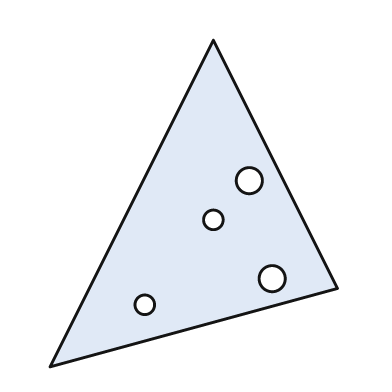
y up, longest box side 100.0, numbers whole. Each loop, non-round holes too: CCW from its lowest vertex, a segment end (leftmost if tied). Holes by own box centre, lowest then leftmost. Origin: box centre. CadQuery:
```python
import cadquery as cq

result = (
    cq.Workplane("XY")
    .moveTo(-44.0, -50.0)
    .lineTo(44.0, -26.0)
    .lineTo(6.0, 50.0)
    .close()
    .moveTo(-15.0, -31.0)
    .circle(3.0)
    .moveTo(24.0, -23.0)
    .circle(4.0)
    .moveTo(6.0, -5.0)
    .circle(3.0)
    .moveTo(17.0, 7.0)
    .circle(4.0)
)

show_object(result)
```